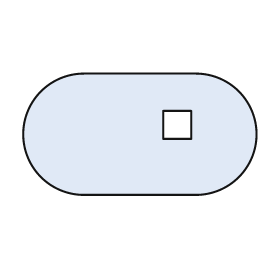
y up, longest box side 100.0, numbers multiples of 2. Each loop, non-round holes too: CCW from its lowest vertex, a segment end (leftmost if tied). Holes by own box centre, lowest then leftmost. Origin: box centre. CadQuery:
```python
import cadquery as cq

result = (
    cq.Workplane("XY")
    .moveTo(-24.0, -26.0)
    .lineTo(24.0, -26.0)
    .threePointArc((50.0, 0.0), (24.0, 26.0))
    .lineTo(-24.0, 26.0)
    .threePointArc((-50.0, 0.0), (-24.0, -26.0))
    .close()
    .moveTo(10.0, -2.0)
    .lineTo(22.0, -2.0)
    .lineTo(22.0, 10.0)
    .lineTo(10.0, 10.0)
    .close()
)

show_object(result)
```